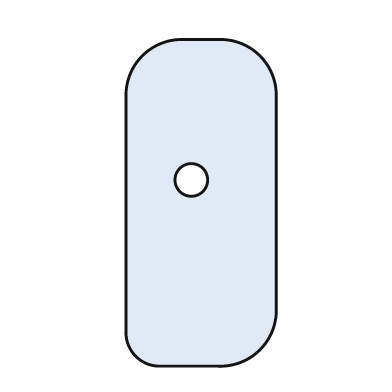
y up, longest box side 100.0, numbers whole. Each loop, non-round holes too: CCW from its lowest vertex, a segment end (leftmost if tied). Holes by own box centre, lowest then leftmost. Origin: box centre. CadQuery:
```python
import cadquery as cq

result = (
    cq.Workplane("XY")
    .moveTo(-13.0, -50.0)
    .lineTo(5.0, -50.0)
    .threePointArc((18.0, -45.0), (23.0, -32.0))
    .lineTo(23.0, 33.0)
    .threePointArc((18.0, 45.0), (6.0, 50.0))
    .lineTo(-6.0, 50.0)
    .threePointArc((-18.0, 45.0), (-23.0, 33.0))
    .lineTo(-23.0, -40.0)
    .threePointArc((-20.0, -47.0), (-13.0, -50.0))
    .close()
    .moveTo(-3.0, 7.0)
    .circle(5.0)
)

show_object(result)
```